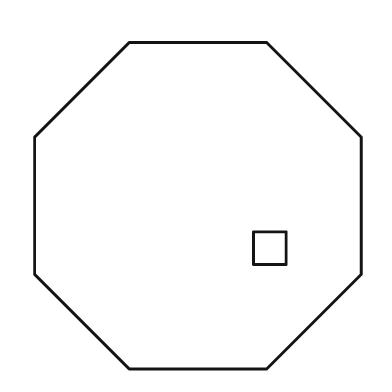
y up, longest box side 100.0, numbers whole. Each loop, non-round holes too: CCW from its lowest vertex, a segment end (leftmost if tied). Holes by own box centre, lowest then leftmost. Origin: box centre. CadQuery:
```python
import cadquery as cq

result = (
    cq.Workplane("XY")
    .moveTo(-21.0, -50.0)
    .lineTo(21.0, -50.0)
    .lineTo(50.0, -21.0)
    .lineTo(50.0, 21.0)
    .lineTo(21.0, 50.0)
    .lineTo(-21.0, 50.0)
    .lineTo(-50.0, 21.0)
    .lineTo(-50.0, -21.0)
    .close()
    .moveTo(17.0, -18.0)
    .lineTo(27.0, -18.0)
    .lineTo(27.0, -8.0)
    .lineTo(17.0, -8.0)
    .close()
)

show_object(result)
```